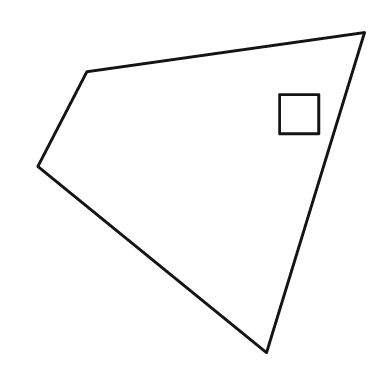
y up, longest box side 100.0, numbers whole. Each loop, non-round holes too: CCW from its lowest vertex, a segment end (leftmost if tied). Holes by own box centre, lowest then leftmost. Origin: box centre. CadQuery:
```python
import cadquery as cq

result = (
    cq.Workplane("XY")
    .moveTo(20.0, -49.0)
    .lineTo(50.0, 49.0)
    .lineTo(-35.0, 37.0)
    .lineTo(-50.0, 8.0)
    .close()
    .moveTo(24.0, 18.0)
    .lineTo(36.0, 18.0)
    .lineTo(36.0, 30.0)
    .lineTo(24.0, 30.0)
    .close()
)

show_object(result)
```